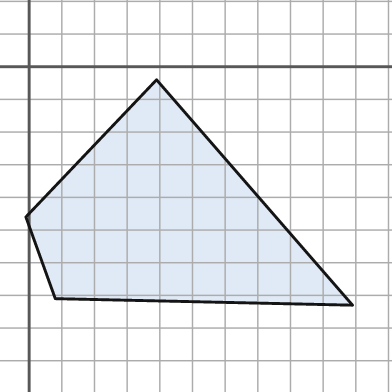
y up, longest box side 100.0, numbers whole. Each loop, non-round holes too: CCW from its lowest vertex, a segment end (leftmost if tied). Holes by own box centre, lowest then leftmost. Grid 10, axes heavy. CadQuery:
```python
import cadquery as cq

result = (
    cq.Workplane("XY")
    .moveTo(99.0, -73.0)
    .lineTo(39.0, -4.0)
    .lineTo(-1.0, -46.0)
    .lineTo(8.0, -71.0)
    .close()
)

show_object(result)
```